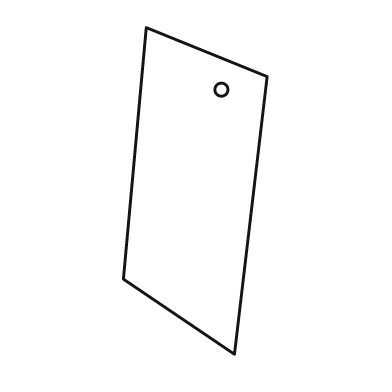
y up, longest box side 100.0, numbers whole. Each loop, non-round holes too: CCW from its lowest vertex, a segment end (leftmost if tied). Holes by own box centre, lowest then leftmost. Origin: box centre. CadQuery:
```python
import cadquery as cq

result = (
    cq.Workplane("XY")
    .moveTo(12.0, -50.0)
    .lineTo(22.0, 35.0)
    .lineTo(-15.0, 50.0)
    .lineTo(-22.0, -27.0)
    .close()
    .moveTo(8.0, 31.0)
    .circle(2.0)
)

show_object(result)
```